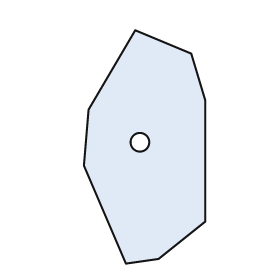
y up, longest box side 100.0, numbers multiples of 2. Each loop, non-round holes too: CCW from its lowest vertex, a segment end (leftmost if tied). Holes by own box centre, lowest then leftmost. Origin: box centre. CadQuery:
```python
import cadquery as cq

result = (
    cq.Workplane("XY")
    .moveTo(-8.0, -50.0)
    .lineTo(6.0, -48.0)
    .lineTo(26.0, -32.0)
    .lineTo(26.0, 20.0)
    .lineTo(20.0, 40.0)
    .lineTo(-4.0, 50.0)
    .lineTo(-24.0, 16.0)
    .lineTo(-26.0, -8.0)
    .close()
    .moveTo(-2.0, 2.0)
    .circle(4.0)
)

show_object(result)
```